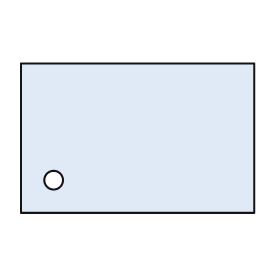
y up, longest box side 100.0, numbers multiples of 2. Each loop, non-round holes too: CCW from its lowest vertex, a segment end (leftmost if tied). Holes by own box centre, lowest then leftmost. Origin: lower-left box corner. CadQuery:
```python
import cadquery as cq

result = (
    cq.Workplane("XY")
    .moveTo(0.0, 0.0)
    .lineTo(100.0, 0.0)
    .lineTo(100.0, 64.0)
    .lineTo(0.0, 64.0)
    .close()
    .moveTo(14.0, 14.0)
    .circle(4.0)
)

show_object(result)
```